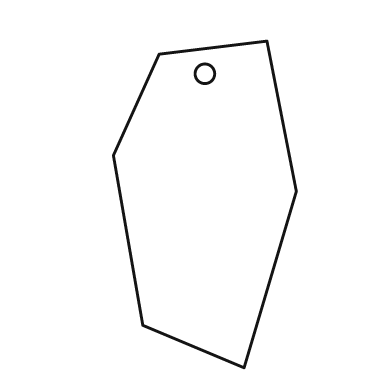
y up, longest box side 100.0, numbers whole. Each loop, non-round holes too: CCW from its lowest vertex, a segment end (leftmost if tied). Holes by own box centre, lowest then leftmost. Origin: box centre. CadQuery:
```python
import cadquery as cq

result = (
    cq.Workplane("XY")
    .moveTo(12.0, -50.0)
    .lineTo(28.0, 4.0)
    .lineTo(19.0, 50.0)
    .lineTo(-14.0, 46.0)
    .lineTo(-28.0, 15.0)
    .lineTo(-19.0, -37.0)
    .close()
    .moveTo(0.0, 40.0)
    .circle(3.0)
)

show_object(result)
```